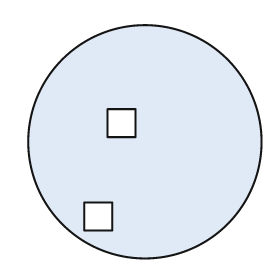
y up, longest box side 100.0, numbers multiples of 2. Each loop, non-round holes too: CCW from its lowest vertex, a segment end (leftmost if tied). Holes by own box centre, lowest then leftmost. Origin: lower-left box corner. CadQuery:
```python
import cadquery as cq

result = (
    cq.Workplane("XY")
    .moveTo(50.0, 50.0)
    .circle(50.0)
    .moveTo(24.0, 12.0)
    .lineTo(36.0, 12.0)
    .lineTo(36.0, 24.0)
    .lineTo(24.0, 24.0)
    .close()
    .moveTo(34.0, 52.0)
    .lineTo(46.0, 52.0)
    .lineTo(46.0, 64.0)
    .lineTo(34.0, 64.0)
    .close()
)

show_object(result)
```